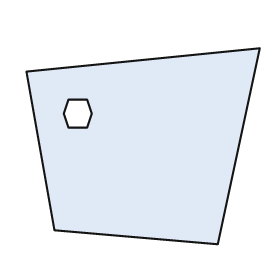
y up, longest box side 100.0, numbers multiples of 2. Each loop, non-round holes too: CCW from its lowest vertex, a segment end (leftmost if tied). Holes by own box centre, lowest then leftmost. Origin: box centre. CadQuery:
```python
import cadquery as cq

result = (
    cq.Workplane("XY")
    .moveTo(32.0, -42.0)
    .lineTo(50.0, 42.0)
    .lineTo(-50.0, 32.0)
    .lineTo(-38.0, -36.0)
    .close()
    .moveTo(-32.0, 8.0)
    .lineTo(-24.0, 8.0)
    .lineTo(-22.0, 14.0)
    .lineTo(-24.0, 20.0)
    .lineTo(-32.0, 20.0)
    .lineTo(-34.0, 14.0)
    .close()
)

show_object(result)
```